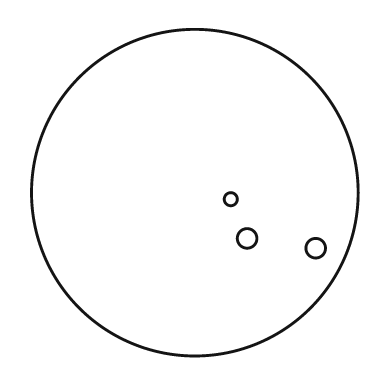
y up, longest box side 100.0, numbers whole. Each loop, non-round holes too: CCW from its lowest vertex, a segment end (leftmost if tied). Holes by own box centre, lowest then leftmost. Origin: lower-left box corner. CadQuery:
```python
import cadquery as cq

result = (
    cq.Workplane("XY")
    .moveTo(50.0, 50.0)
    .circle(50.0)
    .moveTo(87.0, 33.0)
    .circle(3.0)
    .moveTo(66.0, 36.0)
    .circle(3.0)
    .moveTo(61.0, 48.0)
    .circle(2.0)
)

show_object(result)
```